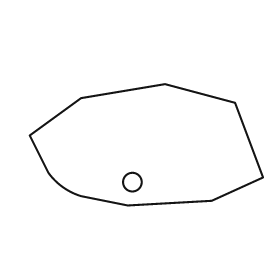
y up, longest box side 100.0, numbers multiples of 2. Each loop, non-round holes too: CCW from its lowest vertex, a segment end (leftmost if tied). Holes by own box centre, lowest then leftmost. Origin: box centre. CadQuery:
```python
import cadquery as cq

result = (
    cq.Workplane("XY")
    .moveTo(-8.0, -26.0)
    .lineTo(28.0, -24.0)
    .lineTo(50.0, -14.0)
    .lineTo(38.0, 18.0)
    .lineTo(8.0, 26.0)
    .lineTo(-28.0, 20.0)
    .lineTo(-50.0, 4.0)
    .lineTo(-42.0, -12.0)
    .threePointArc((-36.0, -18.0), (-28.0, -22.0))
    .close()
    .moveTo(-6.0, -16.0)
    .circle(4.0)
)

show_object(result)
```